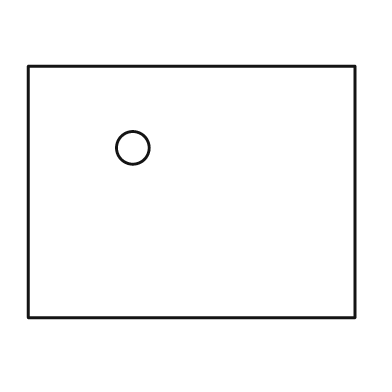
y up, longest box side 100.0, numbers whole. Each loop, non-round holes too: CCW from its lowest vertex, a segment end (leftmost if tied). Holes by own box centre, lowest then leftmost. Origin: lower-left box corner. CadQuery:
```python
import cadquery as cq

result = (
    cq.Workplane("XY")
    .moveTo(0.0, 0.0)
    .lineTo(100.0, 0.0)
    .lineTo(100.0, 77.0)
    .lineTo(0.0, 77.0)
    .close()
    .moveTo(32.0, 52.0)
    .circle(5.0)
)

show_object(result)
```